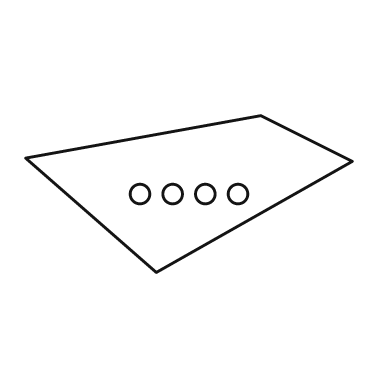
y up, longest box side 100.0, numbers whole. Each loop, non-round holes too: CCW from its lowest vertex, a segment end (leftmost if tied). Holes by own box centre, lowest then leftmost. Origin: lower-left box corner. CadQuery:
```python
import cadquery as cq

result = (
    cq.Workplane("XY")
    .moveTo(40.0, 0.0)
    .lineTo(100.0, 34.0)
    .lineTo(72.0, 48.0)
    .lineTo(0.0, 35.0)
    .close()
    .moveTo(35.0, 24.0)
    .circle(3.0)
    .moveTo(45.0, 24.0)
    .circle(3.0)
    .moveTo(55.0, 24.0)
    .circle(3.0)
    .moveTo(65.0, 24.0)
    .circle(3.0)
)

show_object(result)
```